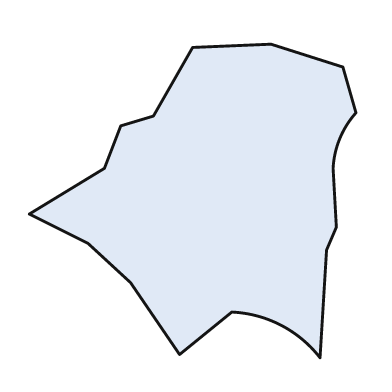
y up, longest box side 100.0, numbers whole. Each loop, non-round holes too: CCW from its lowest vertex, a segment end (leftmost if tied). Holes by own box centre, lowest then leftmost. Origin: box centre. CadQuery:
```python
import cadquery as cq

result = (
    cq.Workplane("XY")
    .moveTo(39.0, -48.0)
    .lineTo(41.0, -15.0)
    .lineTo(44.0, -8.0)
    .lineTo(43.0, 10.0)
    .threePointArc((45.0, 19.0), (50.0, 27.0))
    .lineTo(46.0, 41.0)
    .lineTo(24.0, 48.0)
    .lineTo(0.0, 47.0)
    .lineTo(-12.0, 26.0)
    .lineTo(-22.0, 23.0)
    .lineTo(-27.0, 10.0)
    .lineTo(-50.0, -4.0)
    .lineTo(-32.0, -13.0)
    .lineTo(-19.0, -25.0)
    .lineTo(-4.0, -47.0)
    .lineTo(12.0, -34.0)
    .threePointArc((27.0, -38.0), (39.0, -48.0))
    .close()
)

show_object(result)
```